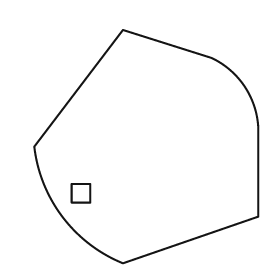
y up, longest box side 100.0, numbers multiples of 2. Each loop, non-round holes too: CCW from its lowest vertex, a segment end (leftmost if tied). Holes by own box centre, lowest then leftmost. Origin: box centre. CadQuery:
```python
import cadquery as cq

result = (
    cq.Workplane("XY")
    .moveTo(-10.0, -50.0)
    .lineTo(48.0, -30.0)
    .lineTo(48.0, 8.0)
    .threePointArc((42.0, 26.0), (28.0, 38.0))
    .lineTo(-10.0, 50.0)
    .lineTo(-48.0, 0.0)
    .threePointArc((-36.0, -30.0), (-10.0, -50.0))
    .close()
    .moveTo(-32.0, -24.0)
    .lineTo(-24.0, -24.0)
    .lineTo(-24.0, -16.0)
    .lineTo(-32.0, -16.0)
    .close()
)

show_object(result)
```